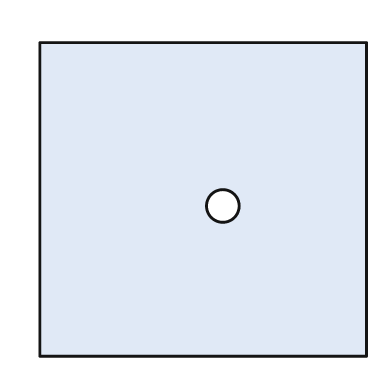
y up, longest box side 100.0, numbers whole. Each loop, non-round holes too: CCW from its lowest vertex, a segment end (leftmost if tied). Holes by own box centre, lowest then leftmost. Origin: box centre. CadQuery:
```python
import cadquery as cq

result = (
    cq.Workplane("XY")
    .moveTo(-50.0, -48.0)
    .lineTo(50.0, -48.0)
    .lineTo(50.0, 48.0)
    .lineTo(-50.0, 48.0)
    .close()
    .moveTo(6.0, -2.0)
    .circle(5.0)
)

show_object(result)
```